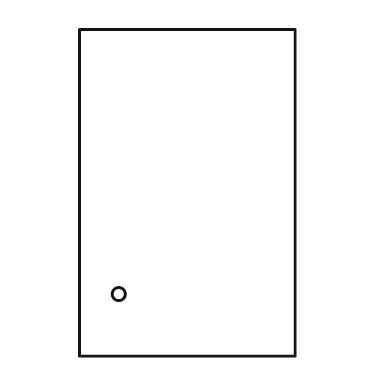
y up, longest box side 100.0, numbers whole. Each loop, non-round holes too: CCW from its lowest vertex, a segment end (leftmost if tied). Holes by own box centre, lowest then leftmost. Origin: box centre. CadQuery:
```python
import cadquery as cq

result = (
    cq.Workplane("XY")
    .moveTo(-33.0, -50.0)
    .lineTo(33.0, -50.0)
    .lineTo(33.0, 50.0)
    .lineTo(-33.0, 50.0)
    .close()
    .moveTo(-21.0, -31.0)
    .circle(2.0)
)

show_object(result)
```